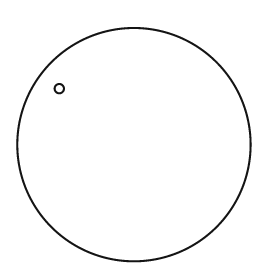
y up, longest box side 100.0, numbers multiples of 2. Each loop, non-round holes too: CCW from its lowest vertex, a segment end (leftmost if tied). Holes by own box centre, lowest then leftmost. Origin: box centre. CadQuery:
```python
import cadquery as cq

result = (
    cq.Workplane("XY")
    .moveTo(0.0, 0.0)
    .circle(50.0)
    .moveTo(-32.0, 24.0)
    .circle(2.0)
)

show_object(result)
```